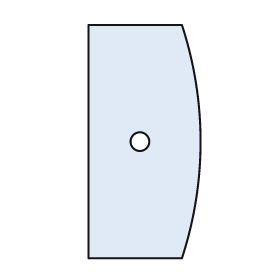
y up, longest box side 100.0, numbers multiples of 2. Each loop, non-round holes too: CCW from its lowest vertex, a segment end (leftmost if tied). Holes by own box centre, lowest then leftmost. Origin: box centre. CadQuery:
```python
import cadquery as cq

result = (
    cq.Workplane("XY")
    .moveTo(-24.0, -50.0)
    .lineTo(16.0, -50.0)
    .threePointArc((24.0, 0.0), (16.0, 50.0))
    .lineTo(-24.0, 50.0)
    .close()
    .moveTo(-2.0, 0.0)
    .circle(4.0)
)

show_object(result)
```